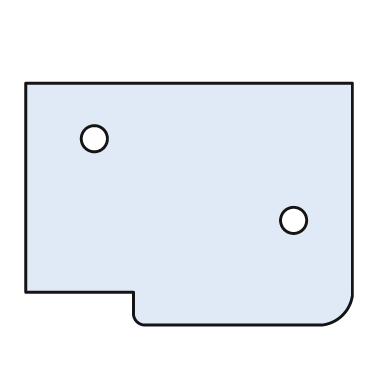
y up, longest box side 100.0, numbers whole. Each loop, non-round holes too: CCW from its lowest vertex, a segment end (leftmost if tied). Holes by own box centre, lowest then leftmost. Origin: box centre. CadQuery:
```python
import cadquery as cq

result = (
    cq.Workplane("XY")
    .moveTo(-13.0, -37.0)
    .lineTo(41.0, -37.0)
    .threePointArc((47.0, -34.0), (50.0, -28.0))
    .lineTo(50.0, 37.0)
    .lineTo(-50.0, 37.0)
    .lineTo(-50.0, -27.0)
    .lineTo(-17.0, -27.0)
    .lineTo(-17.0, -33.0)
    .threePointArc((-16.0, -36.0), (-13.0, -37.0))
    .close()
    .moveTo(32.0, -5.0)
    .circle(4.0)
    .moveTo(-29.0, 20.0)
    .circle(4.0)
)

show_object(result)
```